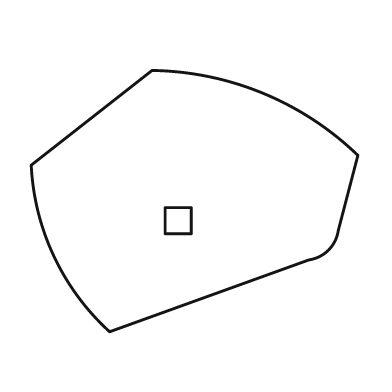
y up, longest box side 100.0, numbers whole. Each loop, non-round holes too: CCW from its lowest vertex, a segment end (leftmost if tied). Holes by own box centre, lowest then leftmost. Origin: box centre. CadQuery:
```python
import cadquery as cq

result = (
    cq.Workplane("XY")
    .moveTo(-26.0, -40.0)
    .lineTo(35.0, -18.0)
    .threePointArc((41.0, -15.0), (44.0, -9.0))
    .lineTo(50.0, 14.0)
    .threePointArc((21.0, 33.0), (-13.0, 40.0))
    .lineTo(-50.0, 11.0)
    .threePointArc((-43.0, -17.0), (-26.0, -40.0))
    .close()
    .moveTo(-9.0, -10.0)
    .lineTo(-1.0, -10.0)
    .lineTo(-1.0, -2.0)
    .lineTo(-9.0, -2.0)
    .close()
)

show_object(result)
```